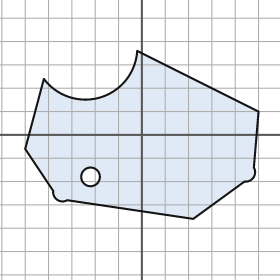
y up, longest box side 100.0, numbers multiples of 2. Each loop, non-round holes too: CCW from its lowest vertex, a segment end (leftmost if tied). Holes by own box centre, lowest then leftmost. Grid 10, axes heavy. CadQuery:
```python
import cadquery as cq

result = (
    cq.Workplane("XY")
    .moveTo(22.0, -36.0)
    .lineTo(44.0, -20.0)
    .threePointArc((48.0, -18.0), (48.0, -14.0))
    .lineTo(50.0, 10.0)
    .lineTo(-2.0, 36.0)
    .threePointArc((-18.0, 16.0), (-42.0, 24.0))
    .lineTo(-50.0, -6.0)
    .lineTo(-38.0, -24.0)
    .threePointArc((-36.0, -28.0), (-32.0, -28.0))
    .close()
    .moveTo(-22.0, -18.0)
    .circle(4.0)
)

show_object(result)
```